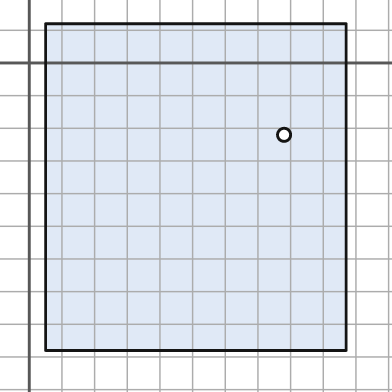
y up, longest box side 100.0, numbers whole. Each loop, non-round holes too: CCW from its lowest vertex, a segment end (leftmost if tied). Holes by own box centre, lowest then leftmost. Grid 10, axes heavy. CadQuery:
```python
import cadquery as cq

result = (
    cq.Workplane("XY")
    .moveTo(5.0, -88.0)
    .lineTo(97.0, -88.0)
    .lineTo(97.0, 12.0)
    .lineTo(5.0, 12.0)
    .close()
    .moveTo(78.0, -22.0)
    .circle(2.0)
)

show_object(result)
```